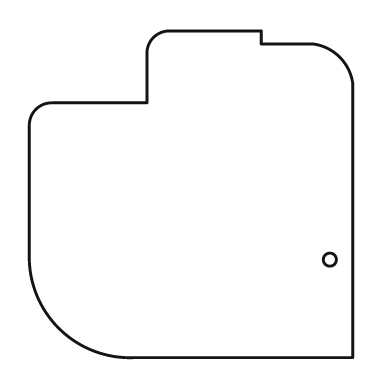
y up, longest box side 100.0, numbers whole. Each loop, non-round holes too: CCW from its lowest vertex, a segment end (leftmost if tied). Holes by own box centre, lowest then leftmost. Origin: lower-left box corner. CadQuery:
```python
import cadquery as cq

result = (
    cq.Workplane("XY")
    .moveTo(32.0, 0.0)
    .lineTo(99.0, 0.0)
    .lineTo(99.0, 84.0)
    .threePointArc((95.0, 92.0), (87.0, 96.0))
    .lineTo(71.0, 96.0)
    .lineTo(71.0, 100.0)
    .lineTo(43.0, 100.0)
    .threePointArc((38.0, 98.0), (36.0, 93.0))
    .lineTo(36.0, 78.0)
    .lineTo(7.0, 78.0)
    .threePointArc((2.0, 76.0), (0.0, 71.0))
    .lineTo(0.0, 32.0)
    .threePointArc((9.0, 9.0), (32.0, 0.0))
    .close()
    .moveTo(92.0, 30.0)
    .circle(2.0)
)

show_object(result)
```